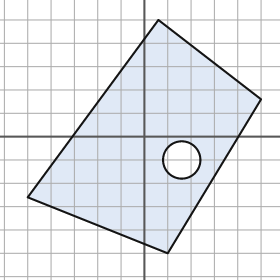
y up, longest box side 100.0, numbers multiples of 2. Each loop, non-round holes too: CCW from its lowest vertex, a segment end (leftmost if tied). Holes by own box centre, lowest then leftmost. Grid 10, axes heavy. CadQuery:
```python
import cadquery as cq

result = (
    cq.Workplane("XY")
    .moveTo(10.0, -50.0)
    .lineTo(50.0, 16.0)
    .lineTo(6.0, 50.0)
    .lineTo(-50.0, -26.0)
    .close()
    .moveTo(16.0, -10.0)
    .circle(8.0)
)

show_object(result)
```